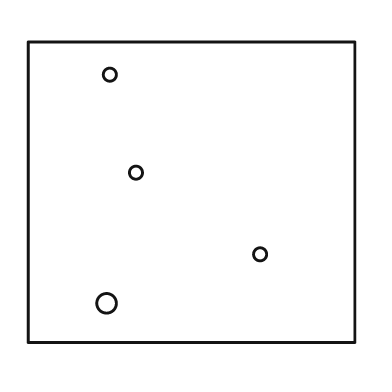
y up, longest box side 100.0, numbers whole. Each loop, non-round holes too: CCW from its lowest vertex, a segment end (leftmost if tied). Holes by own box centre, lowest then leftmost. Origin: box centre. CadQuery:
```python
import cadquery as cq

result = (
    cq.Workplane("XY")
    .moveTo(-50.0, -46.0)
    .lineTo(50.0, -46.0)
    .lineTo(50.0, 46.0)
    .lineTo(-50.0, 46.0)
    .close()
    .moveTo(-26.0, -34.0)
    .circle(3.0)
    .moveTo(21.0, -19.0)
    .circle(2.0)
    .moveTo(-17.0, 6.0)
    .circle(2.0)
    .moveTo(-25.0, 36.0)
    .circle(2.0)
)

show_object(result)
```